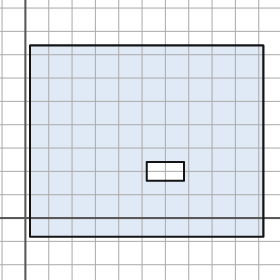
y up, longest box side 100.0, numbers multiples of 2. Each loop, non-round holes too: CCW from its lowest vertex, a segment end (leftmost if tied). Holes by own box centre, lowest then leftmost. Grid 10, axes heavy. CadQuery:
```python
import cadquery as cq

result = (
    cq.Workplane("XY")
    .moveTo(2.0, -8.0)
    .lineTo(102.0, -8.0)
    .lineTo(102.0, 74.0)
    .lineTo(2.0, 74.0)
    .close()
    .moveTo(52.0, 16.0)
    .lineTo(68.0, 16.0)
    .lineTo(68.0, 24.0)
    .lineTo(52.0, 24.0)
    .close()
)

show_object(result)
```